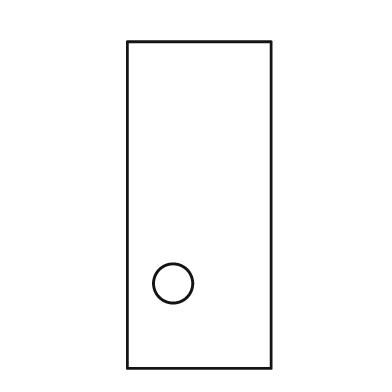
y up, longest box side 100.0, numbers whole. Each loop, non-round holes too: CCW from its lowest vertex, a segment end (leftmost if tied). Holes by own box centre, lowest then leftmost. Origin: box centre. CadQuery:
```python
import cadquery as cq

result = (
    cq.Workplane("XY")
    .moveTo(-22.0, -50.0)
    .lineTo(22.0, -50.0)
    .lineTo(22.0, 50.0)
    .lineTo(-22.0, 50.0)
    .close()
    .moveTo(-8.0, -24.0)
    .circle(6.0)
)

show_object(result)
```